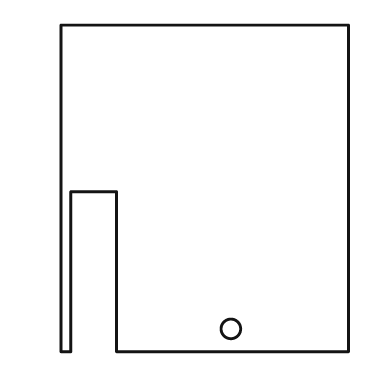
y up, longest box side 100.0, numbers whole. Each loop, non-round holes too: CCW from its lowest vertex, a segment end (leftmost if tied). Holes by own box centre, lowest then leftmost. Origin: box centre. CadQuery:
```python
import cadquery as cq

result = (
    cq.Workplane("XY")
    .moveTo(-44.0, -50.0)
    .lineTo(-41.0, -50.0)
    .lineTo(-41.0, -1.0)
    .lineTo(-27.0, -1.0)
    .lineTo(-27.0, -50.0)
    .lineTo(44.0, -50.0)
    .lineTo(44.0, 50.0)
    .lineTo(-44.0, 50.0)
    .close()
    .moveTo(8.0, -43.0)
    .circle(3.0)
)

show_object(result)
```